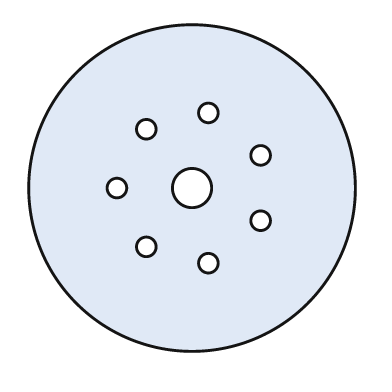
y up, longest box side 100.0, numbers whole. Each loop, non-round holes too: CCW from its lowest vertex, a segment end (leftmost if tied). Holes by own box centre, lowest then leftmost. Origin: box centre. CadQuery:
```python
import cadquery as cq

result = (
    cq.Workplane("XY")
    .moveTo(0.0, 0.0)
    .circle(50.0)
    .moveTo(5.0, -23.0)
    .circle(3.0)
    .moveTo(-14.0, -18.0)
    .circle(3.0)
    .moveTo(21.0, -10.0)
    .circle(3.0)
    .moveTo(-23.0, 0.0)
    .circle(3.0)
    .moveTo(0.0, 0.0)
    .circle(6.0)
    .moveTo(21.0, 10.0)
    .circle(3.0)
    .moveTo(-14.0, 18.0)
    .circle(3.0)
    .moveTo(5.0, 23.0)
    .circle(3.0)
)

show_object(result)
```